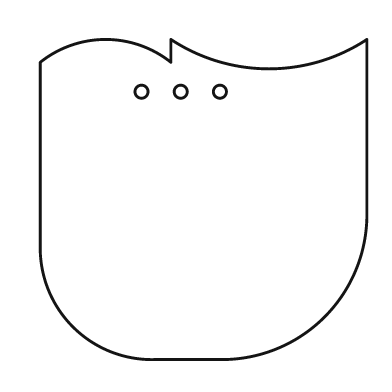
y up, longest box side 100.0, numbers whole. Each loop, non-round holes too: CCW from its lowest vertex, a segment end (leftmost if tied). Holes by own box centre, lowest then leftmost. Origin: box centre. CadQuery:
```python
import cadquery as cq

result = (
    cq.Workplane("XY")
    .moveTo(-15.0, -49.0)
    .lineTo(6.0, -49.0)
    .threePointArc((37.0, -36.0), (50.0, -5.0))
    .lineTo(50.0, 49.0)
    .threePointArc((20.0, 40.0), (-10.0, 49.0))
    .lineTo(-10.0, 42.0)
    .threePointArc((-30.0, 49.0), (-50.0, 42.0))
    .lineTo(-50.0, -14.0)
    .threePointArc((-40.0, -39.0), (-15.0, -49.0))
    .close()
    .moveTo(-19.0, 33.0)
    .circle(2.0)
    .moveTo(-7.0, 33.0)
    .circle(2.0)
    .moveTo(5.0, 33.0)
    .circle(2.0)
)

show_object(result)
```